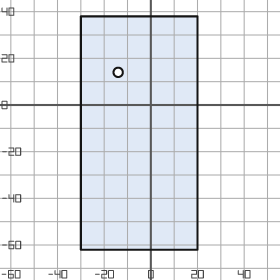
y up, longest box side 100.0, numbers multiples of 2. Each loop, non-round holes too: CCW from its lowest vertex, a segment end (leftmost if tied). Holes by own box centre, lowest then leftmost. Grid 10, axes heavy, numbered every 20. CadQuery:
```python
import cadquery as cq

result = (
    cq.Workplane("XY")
    .moveTo(-30.0, -62.0)
    .lineTo(20.0, -62.0)
    .lineTo(20.0, 38.0)
    .lineTo(-30.0, 38.0)
    .close()
    .moveTo(-14.0, 14.0)
    .circle(2.0)
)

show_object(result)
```